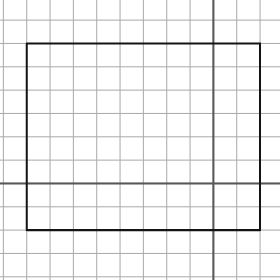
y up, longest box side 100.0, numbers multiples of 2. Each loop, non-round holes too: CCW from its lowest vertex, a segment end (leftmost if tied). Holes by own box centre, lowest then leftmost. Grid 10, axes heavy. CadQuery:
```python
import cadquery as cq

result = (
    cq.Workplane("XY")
    .moveTo(-80.0, -20.0)
    .lineTo(20.0, -20.0)
    .lineTo(20.0, 60.0)
    .lineTo(-80.0, 60.0)
    .close()
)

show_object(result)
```